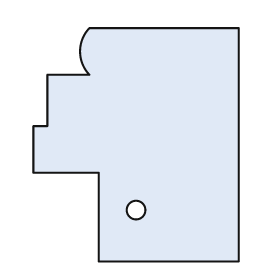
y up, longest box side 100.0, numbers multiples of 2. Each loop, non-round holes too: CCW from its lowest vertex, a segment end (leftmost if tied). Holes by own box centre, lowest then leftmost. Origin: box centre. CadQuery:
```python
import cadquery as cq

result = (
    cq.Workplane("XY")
    .moveTo(-16.0, -50.0)
    .lineTo(44.0, -50.0)
    .lineTo(44.0, 50.0)
    .lineTo(-20.0, 50.0)
    .threePointArc((-24.0, 40.0), (-20.0, 30.0))
    .lineTo(-38.0, 30.0)
    .lineTo(-38.0, 8.0)
    .lineTo(-44.0, 8.0)
    .lineTo(-44.0, -12.0)
    .lineTo(-16.0, -12.0)
    .close()
    .moveTo(0.0, -28.0)
    .circle(4.0)
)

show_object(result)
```